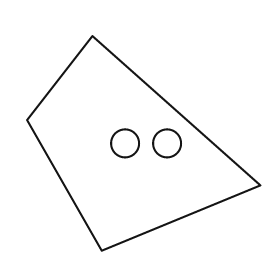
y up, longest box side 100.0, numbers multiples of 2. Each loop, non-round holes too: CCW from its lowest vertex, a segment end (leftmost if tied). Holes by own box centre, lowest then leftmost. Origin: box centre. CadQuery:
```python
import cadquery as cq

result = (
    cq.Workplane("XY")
    .moveTo(-18.0, -46.0)
    .lineTo(50.0, -18.0)
    .lineTo(-22.0, 46.0)
    .lineTo(-50.0, 10.0)
    .close()
    .moveTo(-8.0, 0.0)
    .circle(6.0)
    .moveTo(10.0, 0.0)
    .circle(6.0)
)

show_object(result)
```